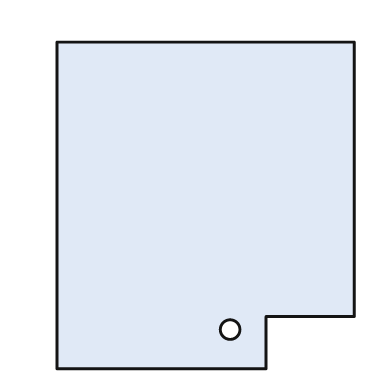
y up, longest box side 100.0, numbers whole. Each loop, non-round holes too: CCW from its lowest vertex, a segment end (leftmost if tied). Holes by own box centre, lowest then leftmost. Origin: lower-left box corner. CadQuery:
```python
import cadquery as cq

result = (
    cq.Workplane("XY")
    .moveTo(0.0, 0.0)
    .lineTo(64.0, 0.0)
    .lineTo(64.0, 16.0)
    .lineTo(91.0, 16.0)
    .lineTo(91.0, 100.0)
    .lineTo(0.0, 100.0)
    .close()
    .moveTo(53.0, 12.0)
    .circle(3.0)
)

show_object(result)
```